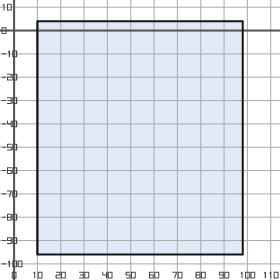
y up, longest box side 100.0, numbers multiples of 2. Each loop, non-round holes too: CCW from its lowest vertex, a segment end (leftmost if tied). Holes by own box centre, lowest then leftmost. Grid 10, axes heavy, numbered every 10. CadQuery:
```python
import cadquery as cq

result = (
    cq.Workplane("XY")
    .moveTo(10.0, -96.0)
    .lineTo(98.0, -96.0)
    .lineTo(98.0, 4.0)
    .lineTo(10.0, 4.0)
    .close()
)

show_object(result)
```